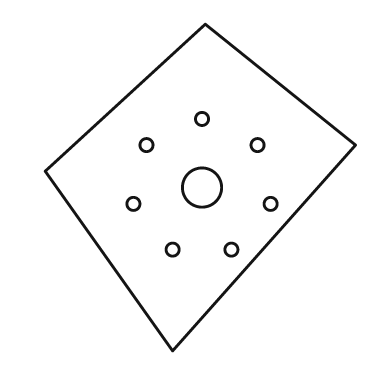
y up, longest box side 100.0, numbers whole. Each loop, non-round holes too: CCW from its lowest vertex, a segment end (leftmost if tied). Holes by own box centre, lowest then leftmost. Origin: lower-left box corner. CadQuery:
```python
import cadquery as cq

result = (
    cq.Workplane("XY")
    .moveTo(39.0, 0.0)
    .lineTo(95.0, 63.0)
    .lineTo(49.0, 100.0)
    .lineTo(0.0, 55.0)
    .close()
    .moveTo(39.0, 31.0)
    .circle(2.0)
    .moveTo(57.0, 31.0)
    .circle(2.0)
    .moveTo(27.0, 45.0)
    .circle(2.0)
    .moveTo(69.0, 45.0)
    .circle(2.0)
    .moveTo(48.0, 50.0)
    .circle(6.0)
    .moveTo(31.0, 63.0)
    .circle(2.0)
    .moveTo(65.0, 63.0)
    .circle(2.0)
    .moveTo(48.0, 71.0)
    .circle(2.0)
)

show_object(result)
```